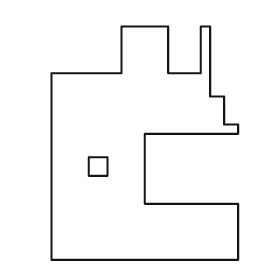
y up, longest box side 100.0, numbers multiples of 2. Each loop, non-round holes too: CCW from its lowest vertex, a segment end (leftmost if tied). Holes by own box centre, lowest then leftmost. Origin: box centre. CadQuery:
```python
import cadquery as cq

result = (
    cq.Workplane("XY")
    .moveTo(-40.0, -50.0)
    .lineTo(40.0, -50.0)
    .lineTo(40.0, -26.0)
    .lineTo(0.0, -26.0)
    .lineTo(0.0, 4.0)
    .lineTo(40.0, 4.0)
    .lineTo(40.0, 8.0)
    .lineTo(34.0, 8.0)
    .lineTo(34.0, 20.0)
    .lineTo(28.0, 20.0)
    .lineTo(28.0, 50.0)
    .lineTo(24.0, 50.0)
    .lineTo(24.0, 30.0)
    .lineTo(10.0, 30.0)
    .lineTo(10.0, 50.0)
    .lineTo(-10.0, 50.0)
    .lineTo(-10.0, 30.0)
    .lineTo(-40.0, 30.0)
    .close()
    .moveTo(-24.0, -14.0)
    .lineTo(-16.0, -14.0)
    .lineTo(-16.0, -6.0)
    .lineTo(-24.0, -6.0)
    .close()
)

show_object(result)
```